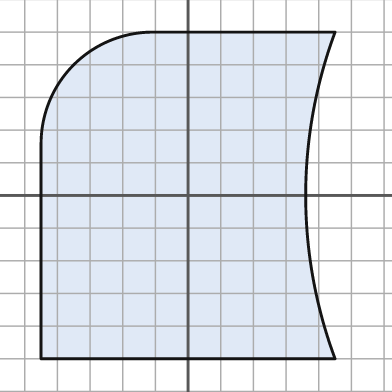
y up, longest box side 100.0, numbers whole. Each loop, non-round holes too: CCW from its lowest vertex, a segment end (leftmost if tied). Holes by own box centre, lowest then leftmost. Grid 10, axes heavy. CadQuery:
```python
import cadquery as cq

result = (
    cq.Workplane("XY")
    .moveTo(-45.0, -50.0)
    .lineTo(45.0, -50.0)
    .threePointArc((36.0, 0.0), (45.0, 50.0))
    .lineTo(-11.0, 50.0)
    .threePointArc((-35.0, 40.0), (-45.0, 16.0))
    .close()
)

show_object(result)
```